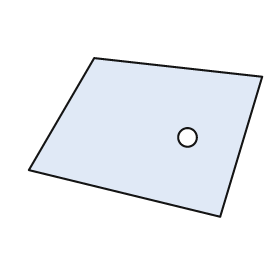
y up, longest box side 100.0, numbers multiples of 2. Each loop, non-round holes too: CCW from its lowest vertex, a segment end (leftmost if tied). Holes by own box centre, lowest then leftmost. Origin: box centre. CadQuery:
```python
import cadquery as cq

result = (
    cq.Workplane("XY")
    .moveTo(32.0, -34.0)
    .lineTo(50.0, 26.0)
    .lineTo(-22.0, 34.0)
    .lineTo(-50.0, -14.0)
    .close()
    .moveTo(18.0, 0.0)
    .circle(4.0)
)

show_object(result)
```